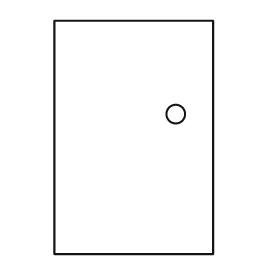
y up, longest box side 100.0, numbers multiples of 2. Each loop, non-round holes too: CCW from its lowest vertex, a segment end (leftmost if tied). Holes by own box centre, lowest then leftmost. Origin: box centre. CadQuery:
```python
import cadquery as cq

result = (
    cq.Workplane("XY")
    .moveTo(-34.0, -50.0)
    .lineTo(34.0, -50.0)
    .lineTo(34.0, 50.0)
    .lineTo(-34.0, 50.0)
    .close()
    .moveTo(18.0, 10.0)
    .circle(4.0)
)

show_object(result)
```